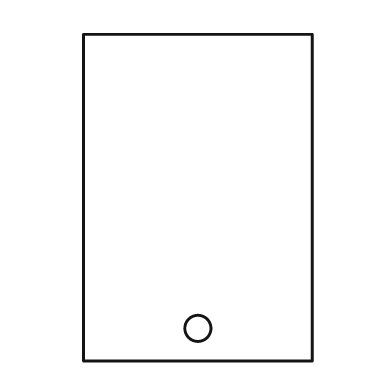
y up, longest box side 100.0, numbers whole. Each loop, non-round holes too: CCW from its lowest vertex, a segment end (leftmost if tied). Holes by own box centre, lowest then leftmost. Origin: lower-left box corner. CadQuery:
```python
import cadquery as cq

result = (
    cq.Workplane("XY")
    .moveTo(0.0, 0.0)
    .lineTo(70.0, 0.0)
    .lineTo(70.0, 100.0)
    .lineTo(0.0, 100.0)
    .close()
    .moveTo(35.0, 10.0)
    .circle(4.0)
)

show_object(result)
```